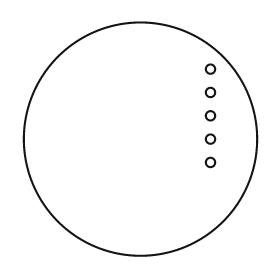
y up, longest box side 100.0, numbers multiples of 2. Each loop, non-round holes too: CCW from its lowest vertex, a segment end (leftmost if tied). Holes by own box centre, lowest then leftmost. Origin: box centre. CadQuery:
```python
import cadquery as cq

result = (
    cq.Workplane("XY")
    .moveTo(0.0, 0.0)
    .circle(50.0)
    .moveTo(30.0, -10.0)
    .circle(2.0)
    .moveTo(30.0, 0.0)
    .circle(2.0)
    .moveTo(30.0, 10.0)
    .circle(2.0)
    .moveTo(30.0, 20.0)
    .circle(2.0)
    .moveTo(30.0, 30.0)
    .circle(2.0)
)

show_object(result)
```